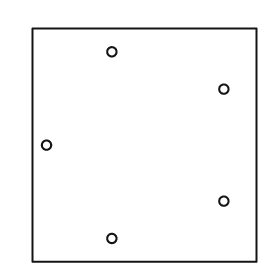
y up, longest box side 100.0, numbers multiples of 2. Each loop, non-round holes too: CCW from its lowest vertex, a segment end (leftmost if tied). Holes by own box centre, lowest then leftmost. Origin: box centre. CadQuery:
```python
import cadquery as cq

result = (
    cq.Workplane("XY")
    .moveTo(-48.0, -50.0)
    .lineTo(48.0, -50.0)
    .lineTo(48.0, 50.0)
    .lineTo(-48.0, 50.0)
    .close()
    .moveTo(-14.0, -40.0)
    .circle(2.0)
    .moveTo(34.0, -24.0)
    .circle(2.0)
    .moveTo(-42.0, 0.0)
    .circle(2.0)
    .moveTo(34.0, 24.0)
    .circle(2.0)
    .moveTo(-14.0, 40.0)
    .circle(2.0)
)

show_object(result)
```